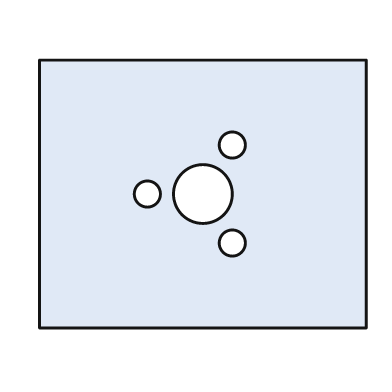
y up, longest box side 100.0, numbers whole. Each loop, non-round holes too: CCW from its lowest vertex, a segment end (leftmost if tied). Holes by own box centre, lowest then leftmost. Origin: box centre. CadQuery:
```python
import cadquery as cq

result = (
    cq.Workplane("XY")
    .moveTo(-50.0, -41.0)
    .lineTo(50.0, -41.0)
    .lineTo(50.0, 41.0)
    .lineTo(-50.0, 41.0)
    .close()
    .moveTo(9.0, -15.0)
    .circle(4.0)
    .moveTo(-17.0, 0.0)
    .circle(4.0)
    .moveTo(0.0, 0.0)
    .circle(9.0)
    .moveTo(9.0, 15.0)
    .circle(4.0)
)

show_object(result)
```